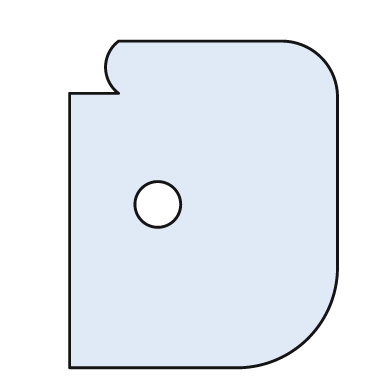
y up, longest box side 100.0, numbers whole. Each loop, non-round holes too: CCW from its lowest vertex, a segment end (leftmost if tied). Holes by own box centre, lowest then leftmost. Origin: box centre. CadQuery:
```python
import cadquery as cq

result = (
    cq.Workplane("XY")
    .moveTo(-41.0, -50.0)
    .lineTo(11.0, -50.0)
    .threePointArc((32.0, -41.0), (41.0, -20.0))
    .lineTo(41.0, 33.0)
    .threePointArc((36.0, 45.0), (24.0, 50.0))
    .lineTo(-26.0, 50.0)
    .threePointArc((-30.0, 42.0), (-26.0, 34.0))
    .lineTo(-41.0, 34.0)
    .close()
    .moveTo(-14.0, 0.0)
    .circle(7.0)
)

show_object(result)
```